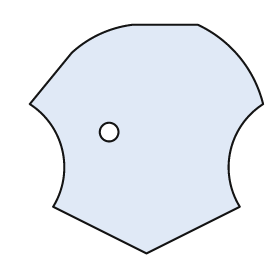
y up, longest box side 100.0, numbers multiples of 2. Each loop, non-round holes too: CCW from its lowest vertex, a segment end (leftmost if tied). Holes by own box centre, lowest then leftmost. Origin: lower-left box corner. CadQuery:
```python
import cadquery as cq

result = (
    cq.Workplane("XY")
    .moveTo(50.0, 0.0)
    .lineTo(90.0, 20.0)
    .threePointArc((86.0, 44.0), (100.0, 64.0))
    .threePointArc((90.0, 84.0), (72.0, 98.0))
    .lineTo(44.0, 98.0)
    .threePointArc((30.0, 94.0), (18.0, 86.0))
    .lineTo(0.0, 64.0)
    .threePointArc((14.0, 44.0), (10.0, 20.0))
    .close()
    .moveTo(34.0, 52.0)
    .circle(4.0)
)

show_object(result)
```